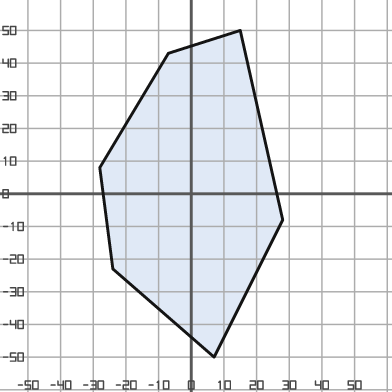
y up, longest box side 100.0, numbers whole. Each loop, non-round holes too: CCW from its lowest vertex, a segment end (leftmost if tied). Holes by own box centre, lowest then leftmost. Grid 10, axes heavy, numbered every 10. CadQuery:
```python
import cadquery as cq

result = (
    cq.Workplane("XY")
    .moveTo(7.0, -50.0)
    .lineTo(28.0, -8.0)
    .lineTo(15.0, 50.0)
    .lineTo(-7.0, 43.0)
    .lineTo(-28.0, 8.0)
    .lineTo(-24.0, -23.0)
    .close()
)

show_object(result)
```